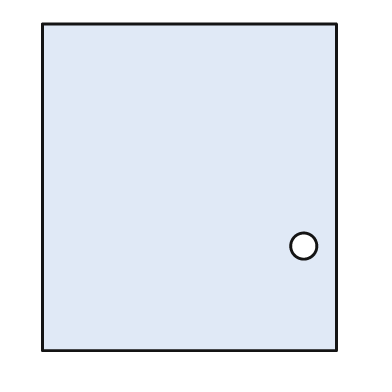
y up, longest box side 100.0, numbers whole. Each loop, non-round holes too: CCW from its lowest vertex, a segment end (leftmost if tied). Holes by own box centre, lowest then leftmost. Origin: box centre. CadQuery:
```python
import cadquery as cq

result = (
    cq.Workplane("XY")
    .moveTo(-45.0, -50.0)
    .lineTo(45.0, -50.0)
    .lineTo(45.0, 50.0)
    .lineTo(-45.0, 50.0)
    .close()
    .moveTo(35.0, -18.0)
    .circle(4.0)
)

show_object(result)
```